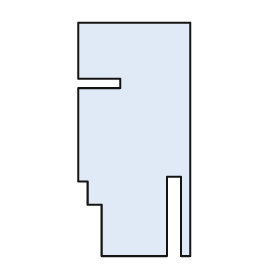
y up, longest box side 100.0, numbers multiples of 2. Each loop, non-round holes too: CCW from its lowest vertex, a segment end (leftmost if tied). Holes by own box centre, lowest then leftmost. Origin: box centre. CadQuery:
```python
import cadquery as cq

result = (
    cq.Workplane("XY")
    .moveTo(-14.0, -50.0)
    .lineTo(14.0, -50.0)
    .lineTo(14.0, -16.0)
    .lineTo(20.0, -16.0)
    .lineTo(20.0, -50.0)
    .lineTo(24.0, -50.0)
    .lineTo(24.0, 50.0)
    .lineTo(-24.0, 50.0)
    .lineTo(-24.0, 26.0)
    .lineTo(-6.0, 26.0)
    .lineTo(-6.0, 22.0)
    .lineTo(-24.0, 22.0)
    .lineTo(-24.0, -18.0)
    .lineTo(-20.0, -18.0)
    .lineTo(-20.0, -28.0)
    .lineTo(-14.0, -28.0)
    .close()
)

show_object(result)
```